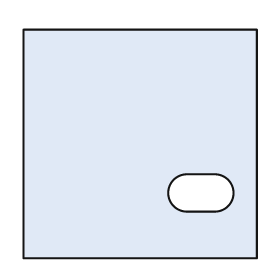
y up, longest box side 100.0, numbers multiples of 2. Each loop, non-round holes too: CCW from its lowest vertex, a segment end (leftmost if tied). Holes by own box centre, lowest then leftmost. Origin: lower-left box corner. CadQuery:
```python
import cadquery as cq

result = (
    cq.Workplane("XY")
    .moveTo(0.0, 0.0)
    .lineTo(100.0, 0.0)
    .lineTo(100.0, 98.0)
    .lineTo(0.0, 98.0)
    .close()
    .moveTo(70.0, 20.0)
    .lineTo(82.0, 20.0)
    .threePointArc((90.0, 28.0), (82.0, 36.0))
    .lineTo(70.0, 36.0)
    .threePointArc((62.0, 28.0), (70.0, 20.0))
    .close()
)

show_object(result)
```